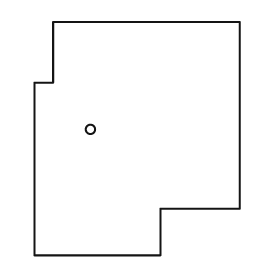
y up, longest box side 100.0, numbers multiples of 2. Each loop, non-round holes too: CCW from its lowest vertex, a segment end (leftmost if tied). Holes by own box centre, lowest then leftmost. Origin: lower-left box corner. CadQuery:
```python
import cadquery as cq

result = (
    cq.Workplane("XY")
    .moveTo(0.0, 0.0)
    .lineTo(54.0, 0.0)
    .lineTo(54.0, 20.0)
    .lineTo(88.0, 20.0)
    .lineTo(88.0, 100.0)
    .lineTo(8.0, 100.0)
    .lineTo(8.0, 74.0)
    .lineTo(0.0, 74.0)
    .close()
    .moveTo(24.0, 54.0)
    .circle(2.0)
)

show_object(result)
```